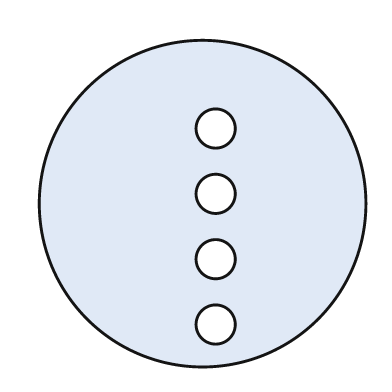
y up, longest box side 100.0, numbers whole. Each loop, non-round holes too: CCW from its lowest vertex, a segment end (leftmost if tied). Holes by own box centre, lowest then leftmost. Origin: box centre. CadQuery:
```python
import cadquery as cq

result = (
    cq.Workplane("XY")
    .moveTo(0.0, 0.0)
    .circle(50.0)
    .moveTo(4.0, -37.0)
    .circle(6.0)
    .moveTo(4.0, -17.0)
    .circle(6.0)
    .moveTo(4.0, 3.0)
    .circle(6.0)
    .moveTo(4.0, 23.0)
    .circle(6.0)
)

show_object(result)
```